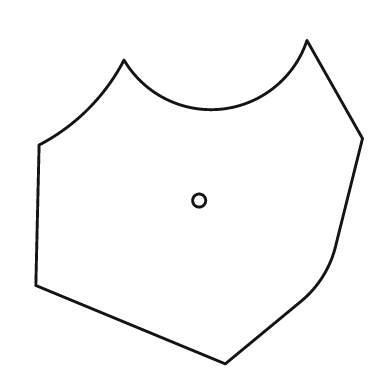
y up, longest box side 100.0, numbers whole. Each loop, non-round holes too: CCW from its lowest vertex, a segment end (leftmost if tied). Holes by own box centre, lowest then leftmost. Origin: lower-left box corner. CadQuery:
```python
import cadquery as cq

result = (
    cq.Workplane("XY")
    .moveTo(58.0, 0.0)
    .lineTo(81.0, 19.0)
    .threePointArc((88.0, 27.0), (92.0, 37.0))
    .lineTo(100.0, 69.0)
    .lineTo(83.0, 99.0)
    .threePointArc((57.0, 78.0), (27.0, 93.0))
    .threePointArc((16.0, 78.0), (1.0, 67.0))
    .lineTo(0.0, 24.0)
    .close()
    .moveTo(50.0, 50.0)
    .circle(2.0)
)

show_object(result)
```